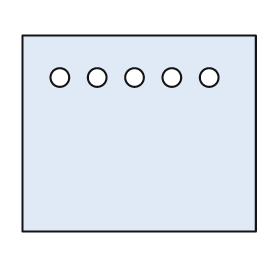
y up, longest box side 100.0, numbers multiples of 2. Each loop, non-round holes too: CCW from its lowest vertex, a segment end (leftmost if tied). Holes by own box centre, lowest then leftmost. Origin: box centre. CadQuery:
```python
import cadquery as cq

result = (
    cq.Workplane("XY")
    .moveTo(-50.0, -42.0)
    .lineTo(50.0, -42.0)
    .lineTo(50.0, 42.0)
    .lineTo(-50.0, 42.0)
    .close()
    .moveTo(-34.0, 24.0)
    .circle(4.0)
    .moveTo(-18.0, 24.0)
    .circle(4.0)
    .moveTo(-2.0, 24.0)
    .circle(4.0)
    .moveTo(14.0, 24.0)
    .circle(4.0)
    .moveTo(30.0, 24.0)
    .circle(4.0)
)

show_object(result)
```